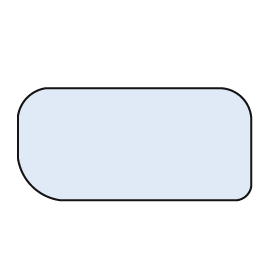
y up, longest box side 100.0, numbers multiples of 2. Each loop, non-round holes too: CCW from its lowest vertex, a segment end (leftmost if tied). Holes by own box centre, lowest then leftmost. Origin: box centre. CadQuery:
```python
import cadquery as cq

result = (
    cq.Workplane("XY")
    .moveTo(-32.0, -24.0)
    .lineTo(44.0, -24.0)
    .threePointArc((48.0, -22.0), (50.0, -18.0))
    .lineTo(50.0, 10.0)
    .threePointArc((46.0, 20.0), (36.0, 24.0))
    .lineTo(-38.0, 24.0)
    .threePointArc((-46.0, 20.0), (-50.0, 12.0))
    .lineTo(-50.0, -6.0)
    .threePointArc((-44.0, -18.0), (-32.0, -24.0))
    .close()
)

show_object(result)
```